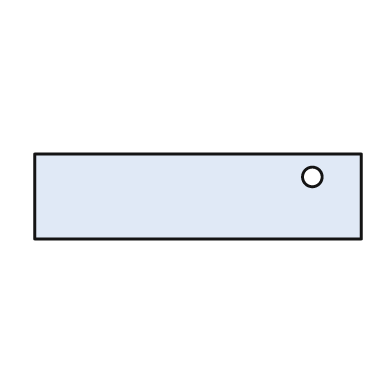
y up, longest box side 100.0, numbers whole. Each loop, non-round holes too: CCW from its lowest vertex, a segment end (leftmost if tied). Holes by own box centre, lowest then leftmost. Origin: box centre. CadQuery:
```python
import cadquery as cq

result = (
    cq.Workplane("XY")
    .moveTo(-50.0, -13.0)
    .lineTo(50.0, -13.0)
    .lineTo(50.0, 13.0)
    .lineTo(-50.0, 13.0)
    .close()
    .moveTo(35.0, 6.0)
    .circle(3.0)
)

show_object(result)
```